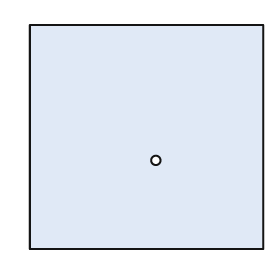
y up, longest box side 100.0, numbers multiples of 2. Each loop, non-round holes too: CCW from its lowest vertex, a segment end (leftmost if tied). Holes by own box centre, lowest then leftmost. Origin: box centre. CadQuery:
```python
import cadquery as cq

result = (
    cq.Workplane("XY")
    .moveTo(-50.0, -48.0)
    .lineTo(50.0, -48.0)
    .lineTo(50.0, 48.0)
    .lineTo(-50.0, 48.0)
    .close()
    .moveTo(4.0, -10.0)
    .circle(2.0)
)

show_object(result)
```